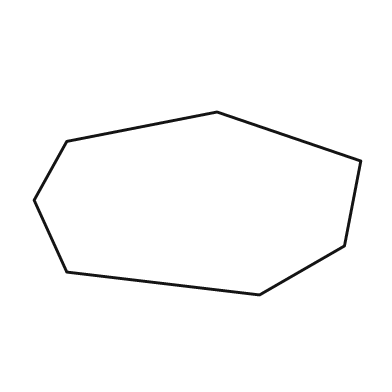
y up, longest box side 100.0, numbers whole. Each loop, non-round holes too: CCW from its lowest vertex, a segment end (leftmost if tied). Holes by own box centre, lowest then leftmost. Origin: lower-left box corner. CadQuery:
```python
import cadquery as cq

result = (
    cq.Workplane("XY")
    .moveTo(69.0, 0.0)
    .lineTo(95.0, 15.0)
    .lineTo(100.0, 41.0)
    .lineTo(56.0, 56.0)
    .lineTo(10.0, 47.0)
    .lineTo(0.0, 29.0)
    .lineTo(10.0, 7.0)
    .close()
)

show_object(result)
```